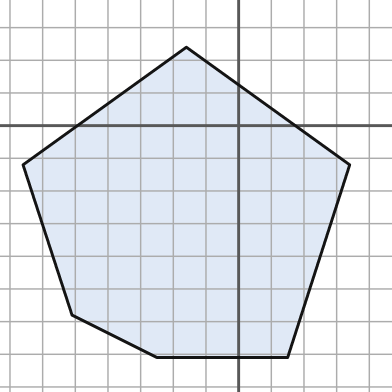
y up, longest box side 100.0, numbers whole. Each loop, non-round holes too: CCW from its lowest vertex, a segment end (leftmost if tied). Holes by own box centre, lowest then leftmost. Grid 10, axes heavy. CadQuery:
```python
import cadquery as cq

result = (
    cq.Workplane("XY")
    .moveTo(-25.0, -71.0)
    .lineTo(15.0, -71.0)
    .lineTo(34.0, -12.0)
    .lineTo(-16.0, 24.0)
    .lineTo(-66.0, -12.0)
    .lineTo(-51.0, -58.0)
    .close()
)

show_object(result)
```